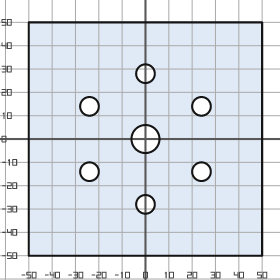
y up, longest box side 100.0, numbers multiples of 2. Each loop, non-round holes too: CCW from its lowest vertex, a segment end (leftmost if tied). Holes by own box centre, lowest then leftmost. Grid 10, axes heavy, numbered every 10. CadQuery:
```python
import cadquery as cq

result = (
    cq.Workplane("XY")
    .moveTo(-50.0, -50.0)
    .lineTo(50.0, -50.0)
    .lineTo(50.0, 50.0)
    .lineTo(-50.0, 50.0)
    .close()
    .moveTo(0.0, -28.0)
    .circle(4.0)
    .moveTo(-24.0, -14.0)
    .circle(4.0)
    .moveTo(24.0, -14.0)
    .circle(4.0)
    .moveTo(0.0, 0.0)
    .circle(6.0)
    .moveTo(-24.0, 14.0)
    .circle(4.0)
    .moveTo(24.0, 14.0)
    .circle(4.0)
    .moveTo(0.0, 28.0)
    .circle(4.0)
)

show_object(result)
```